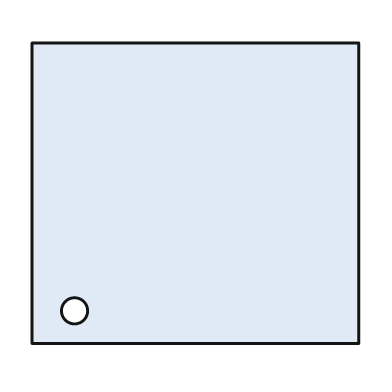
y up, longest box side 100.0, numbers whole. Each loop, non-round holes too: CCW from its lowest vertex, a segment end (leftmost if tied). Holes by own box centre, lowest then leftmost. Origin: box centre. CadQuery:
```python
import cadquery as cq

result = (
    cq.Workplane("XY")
    .moveTo(-50.0, -46.0)
    .lineTo(50.0, -46.0)
    .lineTo(50.0, 46.0)
    .lineTo(-50.0, 46.0)
    .close()
    .moveTo(-37.0, -36.0)
    .circle(4.0)
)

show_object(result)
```